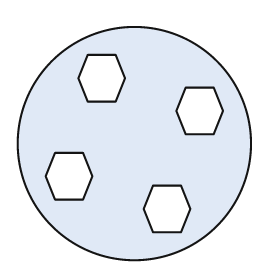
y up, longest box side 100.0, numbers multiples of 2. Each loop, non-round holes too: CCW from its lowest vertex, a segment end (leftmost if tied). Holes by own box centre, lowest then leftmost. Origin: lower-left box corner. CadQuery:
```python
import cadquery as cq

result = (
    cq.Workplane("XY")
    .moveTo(50.0, 50.0)
    .circle(50.0)
    .moveTo(58.0, 12.0)
    .lineTo(70.0, 12.0)
    .lineTo(74.0, 22.0)
    .lineTo(70.0, 32.0)
    .lineTo(58.0, 32.0)
    .lineTo(54.0, 22.0)
    .close()
    .moveTo(16.0, 26.0)
    .lineTo(28.0, 26.0)
    .lineTo(32.0, 36.0)
    .lineTo(28.0, 46.0)
    .lineTo(16.0, 46.0)
    .lineTo(12.0, 36.0)
    .close()
    .moveTo(72.0, 54.0)
    .lineTo(84.0, 54.0)
    .lineTo(88.0, 64.0)
    .lineTo(84.0, 74.0)
    .lineTo(72.0, 74.0)
    .lineTo(68.0, 64.0)
    .close()
    .moveTo(30.0, 68.0)
    .lineTo(42.0, 68.0)
    .lineTo(46.0, 78.0)
    .lineTo(42.0, 88.0)
    .lineTo(30.0, 88.0)
    .lineTo(26.0, 78.0)
    .close()
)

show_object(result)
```